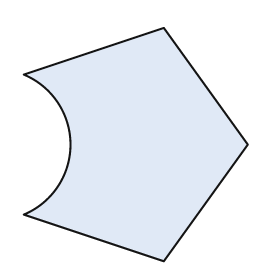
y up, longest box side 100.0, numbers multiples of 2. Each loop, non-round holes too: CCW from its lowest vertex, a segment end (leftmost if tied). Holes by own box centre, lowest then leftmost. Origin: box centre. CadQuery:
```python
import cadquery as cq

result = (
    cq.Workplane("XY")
    .moveTo(12.0, -50.0)
    .lineTo(48.0, 0.0)
    .lineTo(12.0, 50.0)
    .lineTo(-48.0, 30.0)
    .threePointArc((-28.0, 0.0), (-48.0, -30.0))
    .close()
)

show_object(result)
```